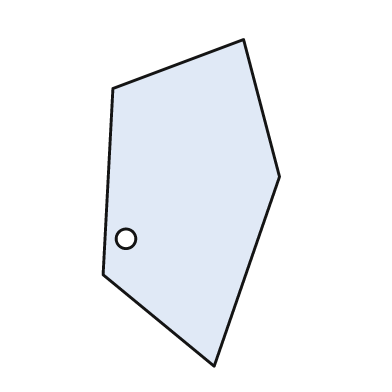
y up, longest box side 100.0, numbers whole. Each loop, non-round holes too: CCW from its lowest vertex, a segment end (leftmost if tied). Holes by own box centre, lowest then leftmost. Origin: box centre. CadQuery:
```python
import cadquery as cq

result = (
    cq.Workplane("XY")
    .moveTo(7.0, -50.0)
    .lineTo(27.0, 8.0)
    .lineTo(16.0, 50.0)
    .lineTo(-24.0, 35.0)
    .lineTo(-27.0, -22.0)
    .close()
    .moveTo(-20.0, -11.0)
    .circle(3.0)
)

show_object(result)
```